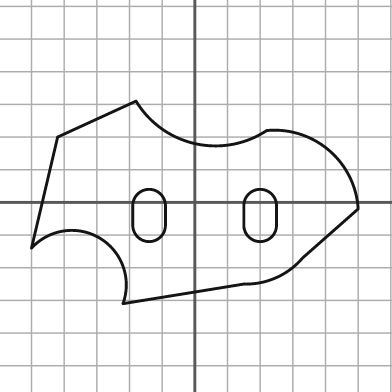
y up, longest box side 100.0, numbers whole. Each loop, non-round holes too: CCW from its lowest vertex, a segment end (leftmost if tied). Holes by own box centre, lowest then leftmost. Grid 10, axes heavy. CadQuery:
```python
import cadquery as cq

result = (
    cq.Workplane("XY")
    .moveTo(-22.0, -31.0)
    .lineTo(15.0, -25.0)
    .threePointArc((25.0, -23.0), (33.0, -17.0))
    .lineTo(50.0, -2.0)
    .threePointArc((41.0, 16.0), (22.0, 22.0))
    .threePointArc((0.0, 18.0), (-18.0, 31.0))
    .lineTo(-42.0, 20.0)
    .lineTo(-50.0, -14.0)
    .threePointArc((-29.0, -11.0), (-22.0, -31.0))
    .close()
    .moveTo(-19.0, -7.0)
    .threePointArc((-14.0, -12.0), (-9.0, -7.0))
    .lineTo(-9.0, -1.0)
    .threePointArc((-14.0, 4.0), (-19.0, -1.0))
    .close()
    .moveTo(15.0, -7.0)
    .threePointArc((20.0, -12.0), (25.0, -7.0))
    .lineTo(25.0, -1.0)
    .threePointArc((20.0, 4.0), (15.0, -1.0))
    .close()
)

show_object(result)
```